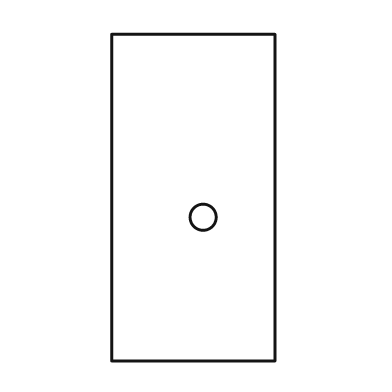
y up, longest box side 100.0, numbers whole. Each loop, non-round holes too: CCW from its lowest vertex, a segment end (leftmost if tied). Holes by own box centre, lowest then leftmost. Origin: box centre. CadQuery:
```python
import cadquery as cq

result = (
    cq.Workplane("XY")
    .moveTo(-25.0, -50.0)
    .lineTo(25.0, -50.0)
    .lineTo(25.0, 50.0)
    .lineTo(-25.0, 50.0)
    .close()
    .moveTo(3.0, -6.0)
    .circle(4.0)
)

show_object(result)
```